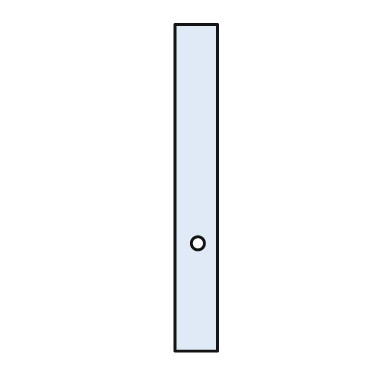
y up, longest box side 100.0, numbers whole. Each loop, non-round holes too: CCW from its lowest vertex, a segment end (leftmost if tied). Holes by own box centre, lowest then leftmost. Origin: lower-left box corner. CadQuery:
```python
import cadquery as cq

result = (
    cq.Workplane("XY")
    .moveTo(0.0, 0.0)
    .lineTo(13.0, 0.0)
    .lineTo(13.0, 100.0)
    .lineTo(0.0, 100.0)
    .close()
    .moveTo(7.0, 33.0)
    .circle(2.0)
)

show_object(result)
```